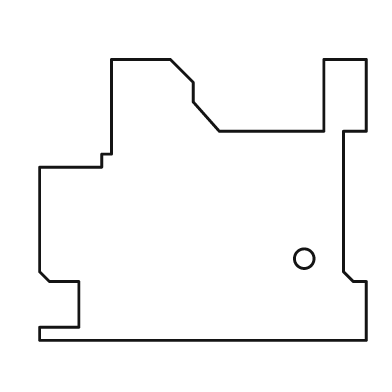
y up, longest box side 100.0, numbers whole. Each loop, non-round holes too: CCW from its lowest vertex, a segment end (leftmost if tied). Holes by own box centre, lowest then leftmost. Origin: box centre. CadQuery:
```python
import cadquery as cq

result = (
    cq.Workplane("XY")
    .moveTo(-50.0, -43.0)
    .lineTo(50.0, -43.0)
    .lineTo(50.0, -25.0)
    .lineTo(46.0, -25.0)
    .lineTo(43.0, -22.0)
    .lineTo(43.0, 21.0)
    .lineTo(50.0, 21.0)
    .lineTo(50.0, 43.0)
    .lineTo(37.0, 43.0)
    .lineTo(37.0, 21.0)
    .lineTo(5.0, 21.0)
    .lineTo(-3.0, 30.0)
    .lineTo(-3.0, 36.0)
    .lineTo(-10.0, 43.0)
    .lineTo(-28.0, 43.0)
    .lineTo(-28.0, 14.0)
    .lineTo(-31.0, 14.0)
    .lineTo(-31.0, 10.0)
    .lineTo(-50.0, 10.0)
    .lineTo(-50.0, -22.0)
    .lineTo(-47.0, -25.0)
    .lineTo(-38.0, -25.0)
    .lineTo(-38.0, -39.0)
    .lineTo(-50.0, -39.0)
    .close()
    .moveTo(31.0, -18.0)
    .circle(3.0)
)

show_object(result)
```